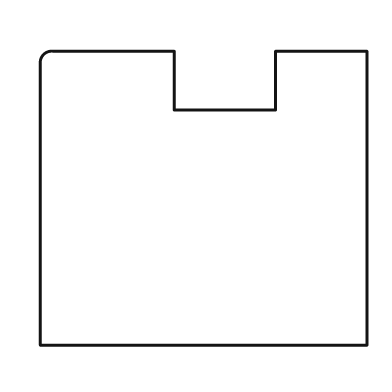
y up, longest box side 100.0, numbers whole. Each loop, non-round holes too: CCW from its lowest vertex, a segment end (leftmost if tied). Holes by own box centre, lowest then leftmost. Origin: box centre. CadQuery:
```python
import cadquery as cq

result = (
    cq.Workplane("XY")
    .moveTo(-50.0, -45.0)
    .lineTo(50.0, -45.0)
    .lineTo(50.0, 45.0)
    .lineTo(22.0, 45.0)
    .lineTo(22.0, 27.0)
    .lineTo(-9.0, 27.0)
    .lineTo(-9.0, 45.0)
    .lineTo(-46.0, 45.0)
    .threePointArc((-49.0, 44.0), (-50.0, 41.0))
    .close()
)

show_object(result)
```